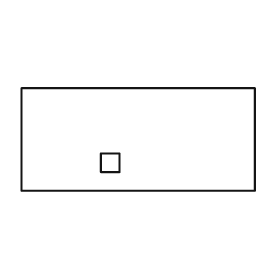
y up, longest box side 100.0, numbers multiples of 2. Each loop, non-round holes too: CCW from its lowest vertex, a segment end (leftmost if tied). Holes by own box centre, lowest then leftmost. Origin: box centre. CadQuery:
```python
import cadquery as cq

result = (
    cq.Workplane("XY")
    .moveTo(-50.0, -22.0)
    .lineTo(50.0, -22.0)
    .lineTo(50.0, 22.0)
    .lineTo(-50.0, 22.0)
    .close()
    .moveTo(-16.0, -14.0)
    .lineTo(-8.0, -14.0)
    .lineTo(-8.0, -6.0)
    .lineTo(-16.0, -6.0)
    .close()
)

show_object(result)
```